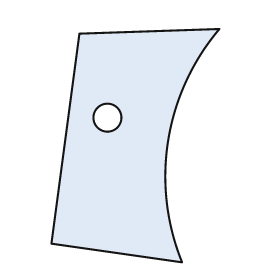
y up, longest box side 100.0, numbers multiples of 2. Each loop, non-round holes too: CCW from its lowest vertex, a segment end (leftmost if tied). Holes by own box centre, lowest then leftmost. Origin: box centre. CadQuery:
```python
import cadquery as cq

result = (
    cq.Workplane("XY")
    .moveTo(20.0, -50.0)
    .threePointArc((14.0, 2.0), (36.0, 50.0))
    .lineTo(-24.0, 48.0)
    .lineTo(-36.0, -42.0)
    .close()
    .moveTo(-12.0, 12.0)
    .circle(6.0)
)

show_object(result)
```